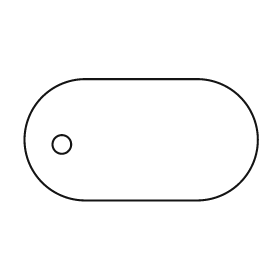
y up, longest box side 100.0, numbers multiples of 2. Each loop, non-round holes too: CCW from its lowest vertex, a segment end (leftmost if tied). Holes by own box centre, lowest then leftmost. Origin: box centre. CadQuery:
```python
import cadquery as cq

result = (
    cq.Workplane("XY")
    .moveTo(-24.0, -26.0)
    .lineTo(24.0, -26.0)
    .threePointArc((50.0, 0.0), (24.0, 26.0))
    .lineTo(-24.0, 26.0)
    .threePointArc((-50.0, 0.0), (-24.0, -26.0))
    .close()
    .moveTo(-34.0, -2.0)
    .circle(4.0)
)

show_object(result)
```